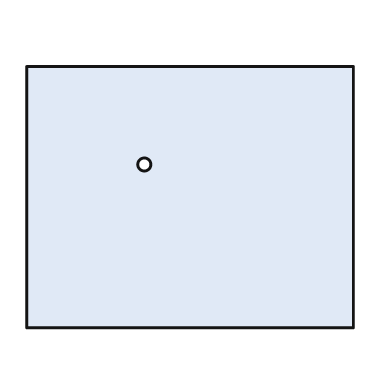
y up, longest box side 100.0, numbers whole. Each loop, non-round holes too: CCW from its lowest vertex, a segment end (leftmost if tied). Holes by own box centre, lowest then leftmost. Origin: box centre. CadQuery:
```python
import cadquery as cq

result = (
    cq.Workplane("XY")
    .moveTo(-50.0, -40.0)
    .lineTo(50.0, -40.0)
    .lineTo(50.0, 40.0)
    .lineTo(-50.0, 40.0)
    .close()
    .moveTo(-14.0, 10.0)
    .circle(2.0)
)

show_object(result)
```